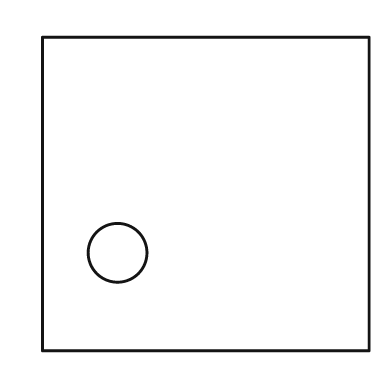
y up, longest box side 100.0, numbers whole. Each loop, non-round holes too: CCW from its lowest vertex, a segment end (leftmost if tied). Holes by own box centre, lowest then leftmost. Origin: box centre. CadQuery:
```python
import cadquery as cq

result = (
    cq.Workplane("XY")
    .moveTo(-50.0, -48.0)
    .lineTo(50.0, -48.0)
    .lineTo(50.0, 48.0)
    .lineTo(-50.0, 48.0)
    .close()
    .moveTo(-27.0, -18.0)
    .circle(9.0)
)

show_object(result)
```